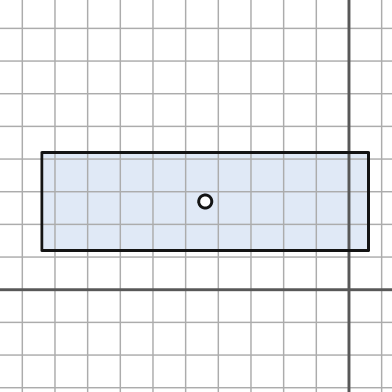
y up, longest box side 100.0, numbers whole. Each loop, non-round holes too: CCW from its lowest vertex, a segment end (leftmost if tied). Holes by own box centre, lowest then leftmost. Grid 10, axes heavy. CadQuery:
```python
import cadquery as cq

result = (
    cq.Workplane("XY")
    .moveTo(-94.0, 12.0)
    .lineTo(6.0, 12.0)
    .lineTo(6.0, 42.0)
    .lineTo(-94.0, 42.0)
    .close()
    .moveTo(-44.0, 27.0)
    .circle(2.0)
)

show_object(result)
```